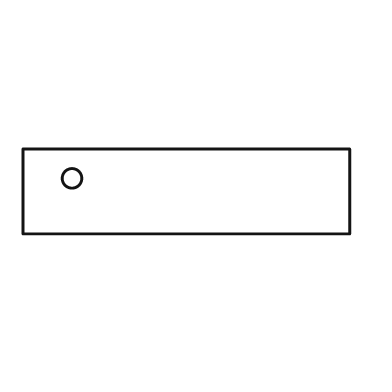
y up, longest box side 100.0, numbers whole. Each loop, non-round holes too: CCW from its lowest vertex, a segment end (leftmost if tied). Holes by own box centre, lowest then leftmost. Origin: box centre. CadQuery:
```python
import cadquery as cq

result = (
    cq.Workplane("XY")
    .moveTo(-50.0, -13.0)
    .lineTo(50.0, -13.0)
    .lineTo(50.0, 13.0)
    .lineTo(-50.0, 13.0)
    .close()
    .moveTo(-35.0, 4.0)
    .circle(3.0)
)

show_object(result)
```